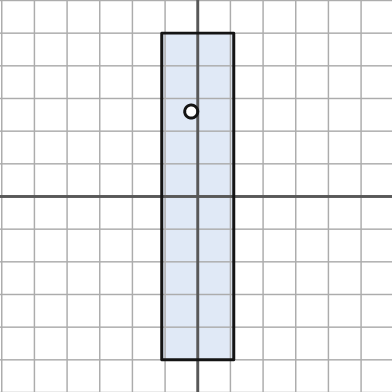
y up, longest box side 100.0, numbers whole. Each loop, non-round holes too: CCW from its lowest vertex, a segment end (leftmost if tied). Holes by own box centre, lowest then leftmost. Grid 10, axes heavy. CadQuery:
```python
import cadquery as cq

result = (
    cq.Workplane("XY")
    .moveTo(-11.0, -50.0)
    .lineTo(11.0, -50.0)
    .lineTo(11.0, 50.0)
    .lineTo(-11.0, 50.0)
    .close()
    .moveTo(-2.0, 26.0)
    .circle(2.0)
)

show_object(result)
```